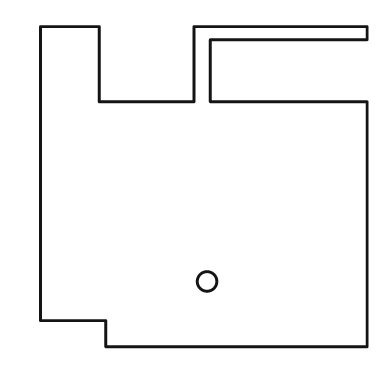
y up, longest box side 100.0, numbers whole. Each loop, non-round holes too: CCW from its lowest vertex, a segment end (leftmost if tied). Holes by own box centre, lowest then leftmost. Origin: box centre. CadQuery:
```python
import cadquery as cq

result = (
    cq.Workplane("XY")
    .moveTo(-30.0, -49.0)
    .lineTo(50.0, -49.0)
    .lineTo(50.0, 26.0)
    .lineTo(2.0, 26.0)
    .lineTo(2.0, 45.0)
    .lineTo(50.0, 45.0)
    .lineTo(50.0, 49.0)
    .lineTo(-3.0, 49.0)
    .lineTo(-3.0, 26.0)
    .lineTo(-32.0, 26.0)
    .lineTo(-32.0, 49.0)
    .lineTo(-50.0, 49.0)
    .lineTo(-50.0, -41.0)
    .lineTo(-30.0, -41.0)
    .close()
    .moveTo(1.0, -29.0)
    .circle(3.0)
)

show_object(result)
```